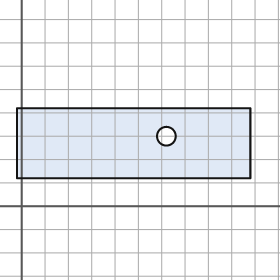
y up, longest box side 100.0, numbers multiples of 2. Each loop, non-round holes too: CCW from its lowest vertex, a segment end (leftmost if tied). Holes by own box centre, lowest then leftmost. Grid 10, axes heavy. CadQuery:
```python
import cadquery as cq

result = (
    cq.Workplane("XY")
    .moveTo(-2.0, 12.0)
    .lineTo(98.0, 12.0)
    .lineTo(98.0, 42.0)
    .lineTo(-2.0, 42.0)
    .close()
    .moveTo(62.0, 30.0)
    .circle(4.0)
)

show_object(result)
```